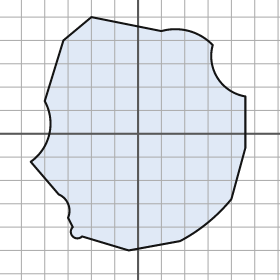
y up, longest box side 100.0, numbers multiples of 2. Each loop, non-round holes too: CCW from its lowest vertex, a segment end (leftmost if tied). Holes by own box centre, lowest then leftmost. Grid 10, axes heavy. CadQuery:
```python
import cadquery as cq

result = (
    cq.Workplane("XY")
    .moveTo(-4.0, -50.0)
    .lineTo(18.0, -46.0)
    .threePointArc((30.0, -38.0), (40.0, -28.0))
    .lineTo(46.0, -6.0)
    .lineTo(46.0, 16.0)
    .threePointArc((34.0, 24.0), (32.0, 38.0))
    .threePointArc((22.0, 44.0), (10.0, 44.0))
    .lineTo(-20.0, 50.0)
    .lineTo(-32.0, 40.0)
    .lineTo(-40.0, 14.0)
    .threePointArc((-38.0, 0.0), (-46.0, -12.0))
    .lineTo(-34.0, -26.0)
    .threePointArc((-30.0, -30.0), (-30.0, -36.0))
    .lineTo(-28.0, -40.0)
    .threePointArc((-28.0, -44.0), (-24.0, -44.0))
    .close()
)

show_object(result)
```